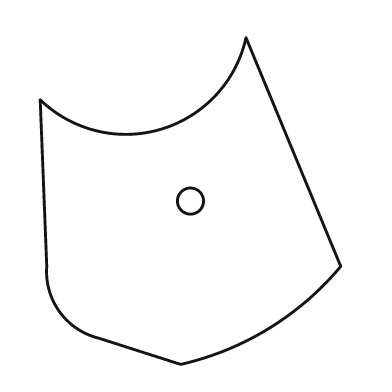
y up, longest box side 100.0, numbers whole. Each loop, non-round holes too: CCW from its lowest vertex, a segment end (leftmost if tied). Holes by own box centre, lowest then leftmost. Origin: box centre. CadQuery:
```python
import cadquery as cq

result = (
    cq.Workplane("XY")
    .moveTo(-3.0, -50.0)
    .threePointArc((24.0, -39.0), (46.0, -20.0))
    .lineTo(17.0, 50.0)
    .threePointArc((-9.0, 22.0), (-46.0, 31.0))
    .lineTo(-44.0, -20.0)
    .threePointArc((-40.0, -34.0), (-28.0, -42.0))
    .close()
    .moveTo(0.0, 0.0)
    .circle(4.0)
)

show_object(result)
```